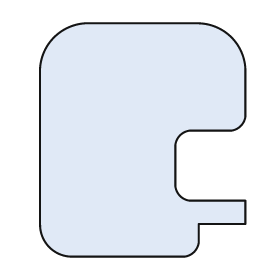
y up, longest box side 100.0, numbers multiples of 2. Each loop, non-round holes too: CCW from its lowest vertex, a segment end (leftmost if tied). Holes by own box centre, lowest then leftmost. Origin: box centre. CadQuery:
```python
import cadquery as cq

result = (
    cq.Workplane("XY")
    .moveTo(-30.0, -50.0)
    .lineTo(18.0, -50.0)
    .threePointArc((22.0, -48.0), (24.0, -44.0))
    .lineTo(24.0, -36.0)
    .lineTo(44.0, -36.0)
    .lineTo(44.0, -26.0)
    .lineTo(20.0, -26.0)
    .threePointArc((16.0, -24.0), (14.0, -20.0))
    .lineTo(14.0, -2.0)
    .threePointArc((16.0, 2.0), (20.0, 4.0))
    .lineTo(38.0, 4.0)
    .threePointArc((42.0, 6.0), (44.0, 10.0))
    .lineTo(44.0, 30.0)
    .threePointArc((38.0, 44.0), (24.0, 50.0))
    .lineTo(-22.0, 50.0)
    .threePointArc((-38.0, 44.0), (-44.0, 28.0))
    .lineTo(-44.0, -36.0)
    .threePointArc((-40.0, -46.0), (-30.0, -50.0))
    .close()
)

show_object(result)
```